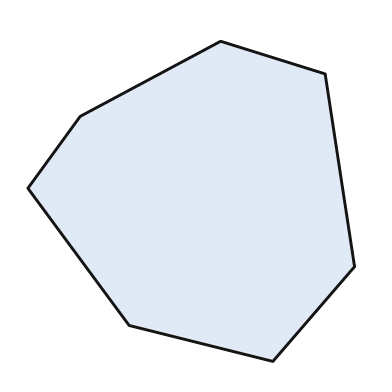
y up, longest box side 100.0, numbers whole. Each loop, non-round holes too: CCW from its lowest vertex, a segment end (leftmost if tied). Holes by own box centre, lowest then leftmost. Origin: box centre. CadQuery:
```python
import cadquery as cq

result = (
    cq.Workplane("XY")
    .moveTo(25.0, -49.0)
    .lineTo(50.0, -20.0)
    .lineTo(41.0, 39.0)
    .lineTo(9.0, 49.0)
    .lineTo(-34.0, 26.0)
    .lineTo(-50.0, 4.0)
    .lineTo(-19.0, -38.0)
    .close()
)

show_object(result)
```